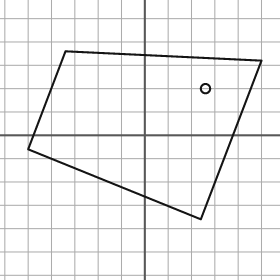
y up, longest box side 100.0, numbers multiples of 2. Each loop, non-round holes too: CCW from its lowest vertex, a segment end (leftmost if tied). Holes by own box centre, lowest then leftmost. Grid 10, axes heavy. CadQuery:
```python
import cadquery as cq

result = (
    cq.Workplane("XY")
    .moveTo(24.0, -36.0)
    .lineTo(50.0, 32.0)
    .lineTo(-34.0, 36.0)
    .lineTo(-50.0, -6.0)
    .close()
    .moveTo(26.0, 20.0)
    .circle(2.0)
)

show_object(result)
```